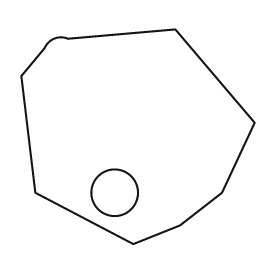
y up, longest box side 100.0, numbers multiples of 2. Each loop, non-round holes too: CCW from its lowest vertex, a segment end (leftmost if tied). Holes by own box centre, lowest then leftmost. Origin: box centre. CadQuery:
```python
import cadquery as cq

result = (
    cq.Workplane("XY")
    .moveTo(-2.0, -46.0)
    .lineTo(18.0, -38.0)
    .lineTo(36.0, -24.0)
    .lineTo(50.0, 6.0)
    .lineTo(16.0, 46.0)
    .lineTo(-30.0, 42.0)
    .threePointArc((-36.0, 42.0), (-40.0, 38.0))
    .lineTo(-50.0, 26.0)
    .lineTo(-44.0, -24.0)
    .close()
    .moveTo(-10.0, -24.0)
    .circle(10.0)
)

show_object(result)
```